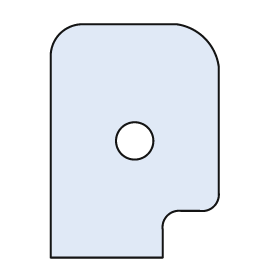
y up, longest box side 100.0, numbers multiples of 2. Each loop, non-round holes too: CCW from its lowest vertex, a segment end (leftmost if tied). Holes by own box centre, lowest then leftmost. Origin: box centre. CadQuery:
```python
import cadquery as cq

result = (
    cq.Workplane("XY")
    .moveTo(-36.0, -50.0)
    .lineTo(12.0, -50.0)
    .lineTo(12.0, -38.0)
    .threePointArc((14.0, -32.0), (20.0, -30.0))
    .lineTo(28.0, -30.0)
    .threePointArc((34.0, -28.0), (36.0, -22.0))
    .lineTo(36.0, 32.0)
    .threePointArc((30.0, 44.0), (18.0, 50.0))
    .lineTo(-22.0, 50.0)
    .threePointArc((-32.0, 46.0), (-36.0, 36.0))
    .close()
    .moveTo(0.0, 0.0)
    .circle(8.0)
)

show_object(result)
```